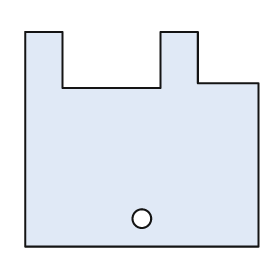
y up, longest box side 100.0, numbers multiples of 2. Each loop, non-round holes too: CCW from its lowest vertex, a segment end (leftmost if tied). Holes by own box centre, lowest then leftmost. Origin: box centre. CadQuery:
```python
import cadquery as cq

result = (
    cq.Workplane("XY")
    .moveTo(-50.0, -46.0)
    .lineTo(50.0, -46.0)
    .lineTo(50.0, 24.0)
    .lineTo(24.0, 24.0)
    .lineTo(24.0, 46.0)
    .lineTo(8.0, 46.0)
    .lineTo(8.0, 22.0)
    .lineTo(-34.0, 22.0)
    .lineTo(-34.0, 46.0)
    .lineTo(-50.0, 46.0)
    .close()
    .moveTo(0.0, -34.0)
    .circle(4.0)
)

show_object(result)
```